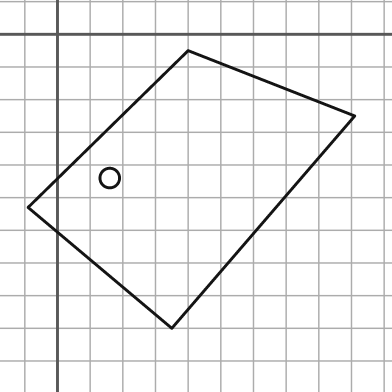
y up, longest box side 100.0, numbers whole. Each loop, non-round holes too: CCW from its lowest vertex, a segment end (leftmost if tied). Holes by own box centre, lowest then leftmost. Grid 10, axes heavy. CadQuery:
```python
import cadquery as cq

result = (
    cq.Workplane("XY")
    .moveTo(35.0, -90.0)
    .lineTo(91.0, -25.0)
    .lineTo(40.0, -5.0)
    .lineTo(-9.0, -53.0)
    .close()
    .moveTo(16.0, -44.0)
    .circle(3.0)
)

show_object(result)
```